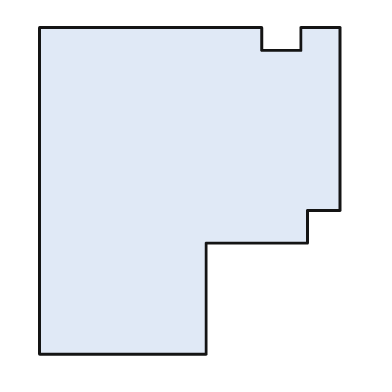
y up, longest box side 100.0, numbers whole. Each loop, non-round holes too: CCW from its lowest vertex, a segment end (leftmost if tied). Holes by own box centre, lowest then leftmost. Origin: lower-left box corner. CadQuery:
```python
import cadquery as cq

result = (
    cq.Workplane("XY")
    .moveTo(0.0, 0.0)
    .lineTo(51.0, 0.0)
    .lineTo(51.0, 34.0)
    .lineTo(82.0, 34.0)
    .lineTo(82.0, 44.0)
    .lineTo(92.0, 44.0)
    .lineTo(92.0, 100.0)
    .lineTo(80.0, 100.0)
    .lineTo(80.0, 93.0)
    .lineTo(68.0, 93.0)
    .lineTo(68.0, 100.0)
    .lineTo(0.0, 100.0)
    .close()
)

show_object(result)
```